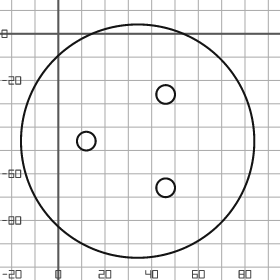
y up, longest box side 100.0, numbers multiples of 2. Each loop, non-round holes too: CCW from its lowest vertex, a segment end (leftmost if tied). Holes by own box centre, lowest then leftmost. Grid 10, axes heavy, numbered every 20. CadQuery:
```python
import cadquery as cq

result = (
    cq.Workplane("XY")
    .moveTo(34.0, -46.0)
    .circle(50.0)
    .moveTo(46.0, -66.0)
    .circle(4.0)
    .moveTo(12.0, -46.0)
    .circle(4.0)
    .moveTo(46.0, -26.0)
    .circle(4.0)
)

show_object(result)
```